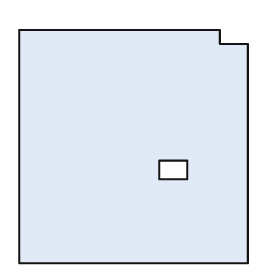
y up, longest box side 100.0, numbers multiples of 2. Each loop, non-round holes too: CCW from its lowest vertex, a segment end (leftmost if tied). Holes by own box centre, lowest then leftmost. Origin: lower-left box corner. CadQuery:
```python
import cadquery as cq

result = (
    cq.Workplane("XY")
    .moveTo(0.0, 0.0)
    .lineTo(98.0, 0.0)
    .lineTo(98.0, 94.0)
    .lineTo(86.0, 94.0)
    .lineTo(86.0, 100.0)
    .lineTo(0.0, 100.0)
    .close()
    .moveTo(60.0, 36.0)
    .lineTo(72.0, 36.0)
    .lineTo(72.0, 44.0)
    .lineTo(60.0, 44.0)
    .close()
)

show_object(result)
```